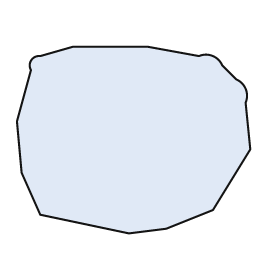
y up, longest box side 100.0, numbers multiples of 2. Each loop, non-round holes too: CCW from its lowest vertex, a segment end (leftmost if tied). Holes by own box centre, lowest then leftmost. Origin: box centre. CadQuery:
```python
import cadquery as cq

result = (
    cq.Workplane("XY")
    .moveTo(-2.0, -40.0)
    .lineTo(14.0, -38.0)
    .lineTo(34.0, -30.0)
    .lineTo(50.0, -4.0)
    .lineTo(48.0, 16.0)
    .threePointArc((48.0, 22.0), (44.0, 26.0))
    .lineTo(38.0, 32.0)
    .threePointArc((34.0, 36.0), (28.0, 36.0))
    .lineTo(6.0, 40.0)
    .lineTo(-26.0, 40.0)
    .lineTo(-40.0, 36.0)
    .threePointArc((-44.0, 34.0), (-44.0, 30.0))
    .lineTo(-50.0, 8.0)
    .lineTo(-48.0, -14.0)
    .lineTo(-40.0, -32.0)
    .close()
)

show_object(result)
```